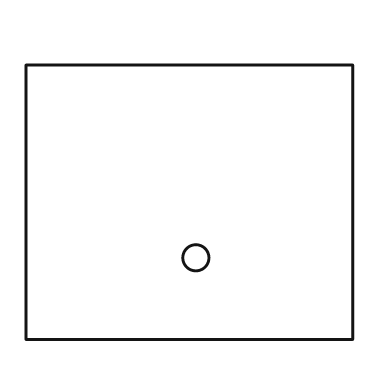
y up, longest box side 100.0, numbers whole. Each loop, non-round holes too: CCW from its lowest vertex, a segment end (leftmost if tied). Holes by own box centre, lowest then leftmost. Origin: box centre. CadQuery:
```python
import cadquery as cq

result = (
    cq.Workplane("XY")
    .moveTo(-50.0, -42.0)
    .lineTo(50.0, -42.0)
    .lineTo(50.0, 42.0)
    .lineTo(-50.0, 42.0)
    .close()
    .moveTo(2.0, -17.0)
    .circle(4.0)
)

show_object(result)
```